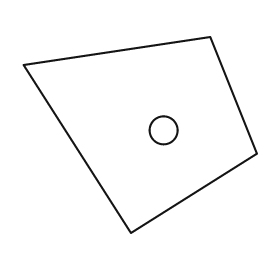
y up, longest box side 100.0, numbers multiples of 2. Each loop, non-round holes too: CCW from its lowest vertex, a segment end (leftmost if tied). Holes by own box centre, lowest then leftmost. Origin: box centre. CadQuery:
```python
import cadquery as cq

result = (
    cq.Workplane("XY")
    .moveTo(-4.0, -42.0)
    .lineTo(50.0, -8.0)
    .lineTo(30.0, 42.0)
    .lineTo(-50.0, 30.0)
    .close()
    .moveTo(10.0, 2.0)
    .circle(6.0)
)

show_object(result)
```